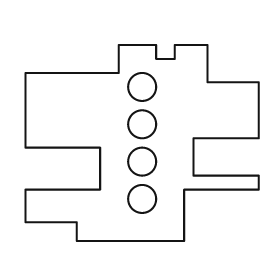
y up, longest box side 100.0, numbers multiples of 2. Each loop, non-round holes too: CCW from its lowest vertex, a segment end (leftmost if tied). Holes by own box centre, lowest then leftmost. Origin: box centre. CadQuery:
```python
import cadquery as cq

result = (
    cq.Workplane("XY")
    .moveTo(-28.0, -42.0)
    .lineTo(18.0, -42.0)
    .lineTo(18.0, -20.0)
    .lineTo(50.0, -20.0)
    .lineTo(50.0, -14.0)
    .lineTo(22.0, -14.0)
    .lineTo(22.0, 2.0)
    .lineTo(50.0, 2.0)
    .lineTo(50.0, 26.0)
    .lineTo(28.0, 26.0)
    .lineTo(28.0, 42.0)
    .lineTo(14.0, 42.0)
    .lineTo(14.0, 36.0)
    .lineTo(6.0, 36.0)
    .lineTo(6.0, 42.0)
    .lineTo(-10.0, 42.0)
    .lineTo(-10.0, 30.0)
    .lineTo(-50.0, 30.0)
    .lineTo(-50.0, -2.0)
    .lineTo(-18.0, -2.0)
    .lineTo(-18.0, -20.0)
    .lineTo(-50.0, -20.0)
    .lineTo(-50.0, -34.0)
    .lineTo(-28.0, -34.0)
    .close()
    .moveTo(0.0, -24.0)
    .circle(6.0)
    .moveTo(0.0, -8.0)
    .circle(6.0)
    .moveTo(0.0, 8.0)
    .circle(6.0)
    .moveTo(0.0, 24.0)
    .circle(6.0)
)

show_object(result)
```